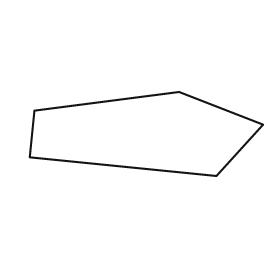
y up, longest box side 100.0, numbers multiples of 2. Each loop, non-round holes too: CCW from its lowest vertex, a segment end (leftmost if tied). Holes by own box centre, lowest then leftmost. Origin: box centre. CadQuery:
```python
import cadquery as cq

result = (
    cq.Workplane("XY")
    .moveTo(30.0, -18.0)
    .lineTo(50.0, 4.0)
    .lineTo(14.0, 18.0)
    .lineTo(-48.0, 10.0)
    .lineTo(-50.0, -10.0)
    .close()
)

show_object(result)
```